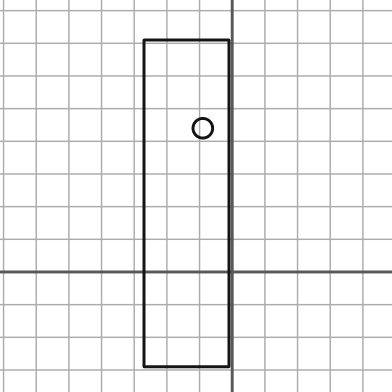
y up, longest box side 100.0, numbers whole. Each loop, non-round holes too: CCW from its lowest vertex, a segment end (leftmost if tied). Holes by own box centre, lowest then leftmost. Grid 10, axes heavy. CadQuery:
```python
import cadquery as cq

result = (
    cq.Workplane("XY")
    .moveTo(-27.0, -29.0)
    .lineTo(-1.0, -29.0)
    .lineTo(-1.0, 71.0)
    .lineTo(-27.0, 71.0)
    .close()
    .moveTo(-9.0, 44.0)
    .circle(3.0)
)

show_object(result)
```